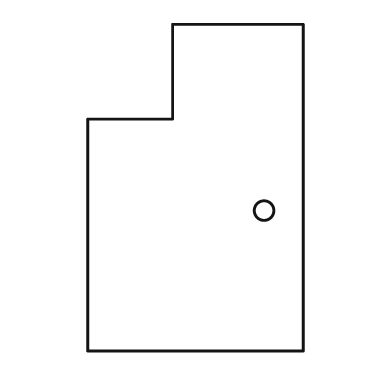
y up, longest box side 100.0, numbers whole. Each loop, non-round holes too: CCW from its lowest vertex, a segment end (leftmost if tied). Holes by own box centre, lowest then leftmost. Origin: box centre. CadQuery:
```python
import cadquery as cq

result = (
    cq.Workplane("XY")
    .moveTo(-33.0, -50.0)
    .lineTo(33.0, -50.0)
    .lineTo(33.0, 50.0)
    .lineTo(-7.0, 50.0)
    .lineTo(-7.0, 21.0)
    .lineTo(-33.0, 21.0)
    .close()
    .moveTo(21.0, -7.0)
    .circle(3.0)
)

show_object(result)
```